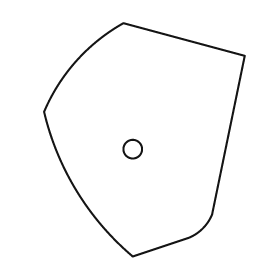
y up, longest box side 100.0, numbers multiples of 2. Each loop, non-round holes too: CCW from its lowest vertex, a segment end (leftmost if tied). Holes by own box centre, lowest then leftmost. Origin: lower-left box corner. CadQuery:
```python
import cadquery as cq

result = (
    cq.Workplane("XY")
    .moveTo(38.0, 0.0)
    .lineTo(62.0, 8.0)
    .threePointArc((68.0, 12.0), (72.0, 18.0))
    .lineTo(86.0, 86.0)
    .lineTo(34.0, 100.0)
    .threePointArc((14.0, 84.0), (0.0, 62.0))
    .threePointArc((14.0, 28.0), (38.0, 0.0))
    .close()
    .moveTo(38.0, 46.0)
    .circle(4.0)
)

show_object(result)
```